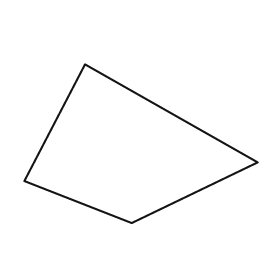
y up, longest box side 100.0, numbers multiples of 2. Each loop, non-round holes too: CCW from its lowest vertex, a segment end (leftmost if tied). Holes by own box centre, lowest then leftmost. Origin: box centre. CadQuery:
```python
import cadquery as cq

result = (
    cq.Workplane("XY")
    .moveTo(-4.0, -34.0)
    .lineTo(50.0, -8.0)
    .lineTo(-24.0, 34.0)
    .lineTo(-50.0, -16.0)
    .close()
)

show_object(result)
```